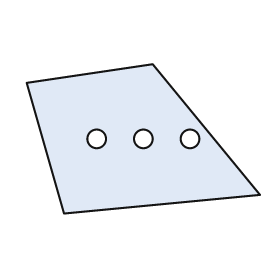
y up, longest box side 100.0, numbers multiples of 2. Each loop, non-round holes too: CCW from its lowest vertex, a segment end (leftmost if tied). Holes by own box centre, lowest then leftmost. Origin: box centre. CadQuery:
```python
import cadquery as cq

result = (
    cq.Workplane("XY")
    .moveTo(-34.0, -32.0)
    .lineTo(50.0, -24.0)
    .lineTo(4.0, 32.0)
    .lineTo(-50.0, 24.0)
    .close()
    .moveTo(-20.0, 0.0)
    .circle(4.0)
    .moveTo(0.0, 0.0)
    .circle(4.0)
    .moveTo(20.0, 0.0)
    .circle(4.0)
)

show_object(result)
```